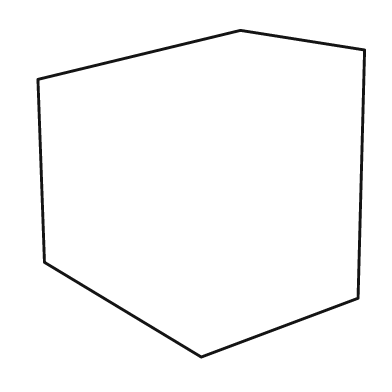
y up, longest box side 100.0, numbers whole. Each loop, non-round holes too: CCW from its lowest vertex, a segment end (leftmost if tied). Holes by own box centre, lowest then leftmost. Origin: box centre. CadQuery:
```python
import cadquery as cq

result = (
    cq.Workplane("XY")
    .moveTo(0.0, -50.0)
    .lineTo(48.0, -32.0)
    .lineTo(50.0, 44.0)
    .lineTo(12.0, 50.0)
    .lineTo(-50.0, 35.0)
    .lineTo(-48.0, -21.0)
    .close()
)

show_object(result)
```